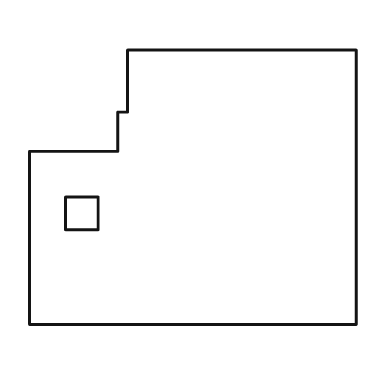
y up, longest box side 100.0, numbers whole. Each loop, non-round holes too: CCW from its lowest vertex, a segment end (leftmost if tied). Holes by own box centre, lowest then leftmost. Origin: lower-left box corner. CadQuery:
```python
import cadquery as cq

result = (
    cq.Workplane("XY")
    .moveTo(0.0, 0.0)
    .lineTo(100.0, 0.0)
    .lineTo(100.0, 84.0)
    .lineTo(30.0, 84.0)
    .lineTo(30.0, 65.0)
    .lineTo(27.0, 65.0)
    .lineTo(27.0, 53.0)
    .lineTo(0.0, 53.0)
    .close()
    .moveTo(11.0, 29.0)
    .lineTo(21.0, 29.0)
    .lineTo(21.0, 39.0)
    .lineTo(11.0, 39.0)
    .close()
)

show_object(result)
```